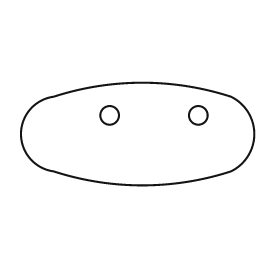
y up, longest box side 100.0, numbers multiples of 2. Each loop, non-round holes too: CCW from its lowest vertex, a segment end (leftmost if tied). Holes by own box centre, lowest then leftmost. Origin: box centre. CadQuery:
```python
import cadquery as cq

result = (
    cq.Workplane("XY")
    .moveTo(-36.0, -16.0)
    .threePointArc((2.0, -22.0), (40.0, -16.0))
    .threePointArc((50.0, 0.0), (40.0, 16.0))
    .threePointArc((2.0, 22.0), (-36.0, 16.0))
    .threePointArc((-50.0, 0.0), (-36.0, -16.0))
    .close()
    .moveTo(-12.0, 8.0)
    .circle(4.0)
    .moveTo(26.0, 8.0)
    .circle(4.0)
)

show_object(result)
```